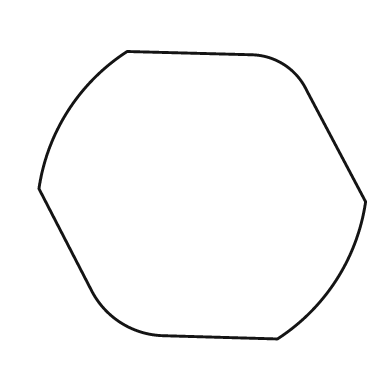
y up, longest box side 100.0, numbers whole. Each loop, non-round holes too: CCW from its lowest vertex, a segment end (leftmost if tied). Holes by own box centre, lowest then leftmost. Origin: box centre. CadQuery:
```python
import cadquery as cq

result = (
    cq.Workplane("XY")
    .moveTo(23.0, -44.0)
    .threePointArc((41.0, -26.0), (50.0, -2.0))
    .lineTo(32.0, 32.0)
    .threePointArc((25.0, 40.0), (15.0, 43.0))
    .lineTo(-23.0, 44.0)
    .threePointArc((-41.0, 26.0), (-50.0, 2.0))
    .lineTo(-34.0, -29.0)
    .threePointArc((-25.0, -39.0), (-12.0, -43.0))
    .close()
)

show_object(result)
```